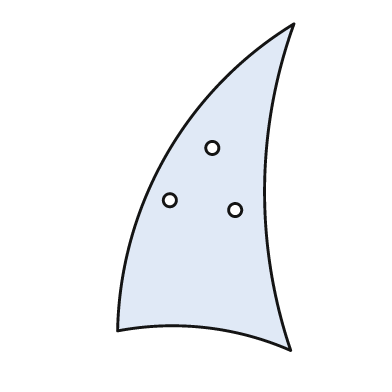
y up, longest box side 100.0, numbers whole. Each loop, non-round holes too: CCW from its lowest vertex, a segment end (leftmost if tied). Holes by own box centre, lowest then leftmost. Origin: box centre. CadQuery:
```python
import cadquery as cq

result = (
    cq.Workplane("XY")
    .moveTo(26.0, -50.0)
    .threePointArc((18.0, 0.0), (27.0, 50.0))
    .threePointArc((-12.0, 10.0), (-27.0, -44.0))
    .threePointArc((0.0, -43.0), (26.0, -50.0))
    .close()
    .moveTo(9.0, -7.0)
    .circle(2.0)
    .moveTo(-11.0, -4.0)
    .circle(2.0)
    .moveTo(2.0, 12.0)
    .circle(2.0)
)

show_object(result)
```